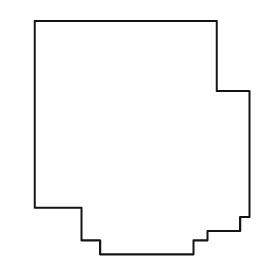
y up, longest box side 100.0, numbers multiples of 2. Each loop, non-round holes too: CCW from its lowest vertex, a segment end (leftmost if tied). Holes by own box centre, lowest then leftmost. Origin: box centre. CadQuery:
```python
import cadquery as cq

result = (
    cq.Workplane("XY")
    .moveTo(-18.0, -50.0)
    .lineTo(22.0, -50.0)
    .lineTo(22.0, -44.0)
    .lineTo(28.0, -44.0)
    .lineTo(28.0, -40.0)
    .lineTo(42.0, -40.0)
    .lineTo(42.0, -34.0)
    .lineTo(46.0, -34.0)
    .lineTo(46.0, 20.0)
    .lineTo(32.0, 20.0)
    .lineTo(32.0, 50.0)
    .lineTo(-46.0, 50.0)
    .lineTo(-46.0, -30.0)
    .lineTo(-26.0, -30.0)
    .lineTo(-26.0, -44.0)
    .lineTo(-18.0, -44.0)
    .close()
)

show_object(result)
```